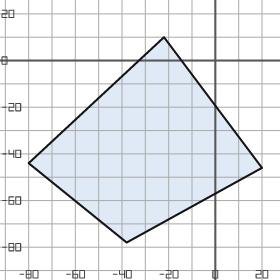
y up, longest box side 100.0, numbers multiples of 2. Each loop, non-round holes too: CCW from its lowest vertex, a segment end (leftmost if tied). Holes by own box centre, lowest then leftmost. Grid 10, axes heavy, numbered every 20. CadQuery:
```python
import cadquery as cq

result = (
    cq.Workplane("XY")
    .moveTo(-38.0, -78.0)
    .lineTo(20.0, -46.0)
    .lineTo(-22.0, 10.0)
    .lineTo(-80.0, -44.0)
    .close()
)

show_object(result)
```